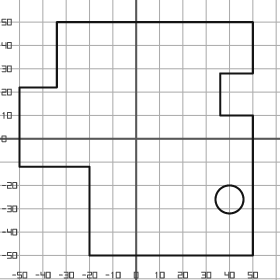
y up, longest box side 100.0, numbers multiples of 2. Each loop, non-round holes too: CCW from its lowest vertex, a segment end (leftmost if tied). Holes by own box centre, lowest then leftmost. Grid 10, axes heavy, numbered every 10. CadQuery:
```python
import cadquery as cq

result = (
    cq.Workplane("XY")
    .moveTo(-20.0, -50.0)
    .lineTo(50.0, -50.0)
    .lineTo(50.0, 10.0)
    .lineTo(36.0, 10.0)
    .lineTo(36.0, 28.0)
    .lineTo(50.0, 28.0)
    .lineTo(50.0, 50.0)
    .lineTo(-34.0, 50.0)
    .lineTo(-34.0, 22.0)
    .lineTo(-50.0, 22.0)
    .lineTo(-50.0, -12.0)
    .lineTo(-20.0, -12.0)
    .close()
    .moveTo(40.0, -26.0)
    .circle(6.0)
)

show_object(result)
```